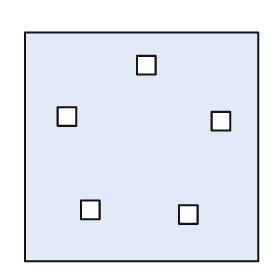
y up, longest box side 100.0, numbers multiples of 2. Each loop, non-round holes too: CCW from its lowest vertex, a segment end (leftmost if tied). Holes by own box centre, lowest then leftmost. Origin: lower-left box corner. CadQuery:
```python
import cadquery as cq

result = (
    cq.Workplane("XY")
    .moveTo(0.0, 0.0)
    .lineTo(100.0, 0.0)
    .lineTo(100.0, 98.0)
    .lineTo(0.0, 98.0)
    .close()
    .moveTo(66.0, 16.0)
    .lineTo(74.0, 16.0)
    .lineTo(74.0, 24.0)
    .lineTo(66.0, 24.0)
    .close()
    .moveTo(24.0, 18.0)
    .lineTo(32.0, 18.0)
    .lineTo(32.0, 26.0)
    .lineTo(24.0, 26.0)
    .close()
    .moveTo(80.0, 56.0)
    .lineTo(88.0, 56.0)
    .lineTo(88.0, 64.0)
    .lineTo(80.0, 64.0)
    .close()
    .moveTo(14.0, 58.0)
    .lineTo(22.0, 58.0)
    .lineTo(22.0, 66.0)
    .lineTo(14.0, 66.0)
    .close()
    .moveTo(48.0, 80.0)
    .lineTo(56.0, 80.0)
    .lineTo(56.0, 88.0)
    .lineTo(48.0, 88.0)
    .close()
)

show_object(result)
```